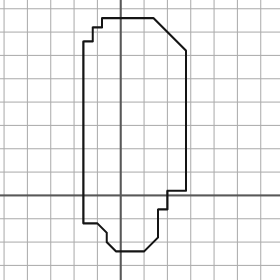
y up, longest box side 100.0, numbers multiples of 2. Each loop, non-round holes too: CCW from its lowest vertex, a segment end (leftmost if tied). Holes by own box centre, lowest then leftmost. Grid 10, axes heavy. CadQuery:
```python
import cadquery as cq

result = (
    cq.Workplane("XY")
    .moveTo(-2.0, -24.0)
    .lineTo(10.0, -24.0)
    .lineTo(16.0, -18.0)
    .lineTo(16.0, -6.0)
    .lineTo(20.0, -6.0)
    .lineTo(20.0, 2.0)
    .lineTo(28.0, 2.0)
    .lineTo(28.0, 62.0)
    .lineTo(14.0, 76.0)
    .lineTo(-8.0, 76.0)
    .lineTo(-8.0, 72.0)
    .lineTo(-12.0, 72.0)
    .lineTo(-12.0, 66.0)
    .lineTo(-16.0, 66.0)
    .lineTo(-16.0, -12.0)
    .lineTo(-10.0, -12.0)
    .lineTo(-6.0, -16.0)
    .lineTo(-6.0, -20.0)
    .close()
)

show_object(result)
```